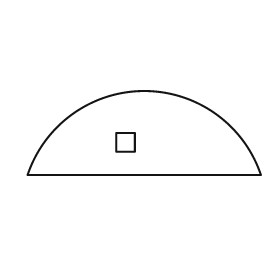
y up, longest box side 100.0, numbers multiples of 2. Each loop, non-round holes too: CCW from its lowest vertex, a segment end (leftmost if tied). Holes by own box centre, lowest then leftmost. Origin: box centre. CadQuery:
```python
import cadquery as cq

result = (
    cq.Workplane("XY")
    .moveTo(-50.0, -18.0)
    .lineTo(50.0, -18.0)
    .threePointArc((0.0, 18.0), (-50.0, -18.0))
    .close()
    .moveTo(-12.0, -8.0)
    .lineTo(-4.0, -8.0)
    .lineTo(-4.0, 0.0)
    .lineTo(-12.0, 0.0)
    .close()
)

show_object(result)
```